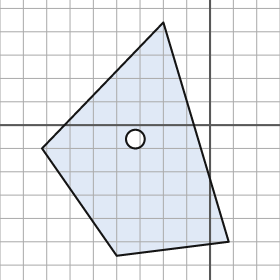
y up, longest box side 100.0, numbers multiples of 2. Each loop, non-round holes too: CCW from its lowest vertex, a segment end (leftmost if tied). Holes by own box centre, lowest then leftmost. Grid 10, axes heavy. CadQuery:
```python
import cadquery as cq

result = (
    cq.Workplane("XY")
    .moveTo(-40.0, -56.0)
    .lineTo(8.0, -50.0)
    .lineTo(-20.0, 44.0)
    .lineTo(-72.0, -10.0)
    .close()
    .moveTo(-32.0, -6.0)
    .circle(4.0)
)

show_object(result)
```